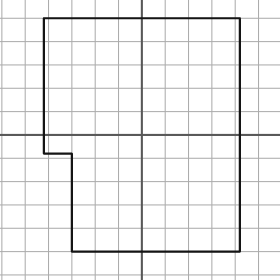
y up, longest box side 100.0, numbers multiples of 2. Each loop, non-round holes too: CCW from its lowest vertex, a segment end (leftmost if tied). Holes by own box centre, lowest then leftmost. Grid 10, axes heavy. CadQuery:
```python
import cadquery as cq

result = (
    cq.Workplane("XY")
    .moveTo(-30.0, -50.0)
    .lineTo(42.0, -50.0)
    .lineTo(42.0, 50.0)
    .lineTo(-42.0, 50.0)
    .lineTo(-42.0, -8.0)
    .lineTo(-30.0, -8.0)
    .close()
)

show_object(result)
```